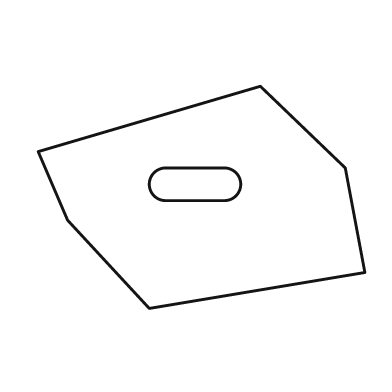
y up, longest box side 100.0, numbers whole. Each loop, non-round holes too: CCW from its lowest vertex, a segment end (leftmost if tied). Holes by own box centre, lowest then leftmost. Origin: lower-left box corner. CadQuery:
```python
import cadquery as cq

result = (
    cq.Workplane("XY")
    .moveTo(34.0, 0.0)
    .lineTo(100.0, 11.0)
    .lineTo(94.0, 43.0)
    .lineTo(68.0, 68.0)
    .lineTo(0.0, 48.0)
    .lineTo(9.0, 27.0)
    .close()
    .moveTo(39.0, 33.0)
    .lineTo(57.0, 33.0)
    .threePointArc((62.0, 38.0), (57.0, 43.0))
    .lineTo(39.0, 43.0)
    .threePointArc((34.0, 38.0), (39.0, 33.0))
    .close()
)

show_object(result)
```